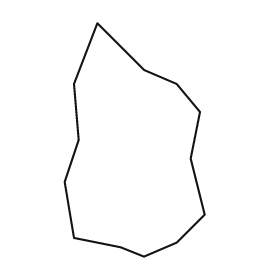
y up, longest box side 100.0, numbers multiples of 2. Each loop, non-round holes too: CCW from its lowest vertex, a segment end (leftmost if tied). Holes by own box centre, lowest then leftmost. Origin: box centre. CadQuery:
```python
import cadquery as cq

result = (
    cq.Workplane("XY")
    .moveTo(4.0, -50.0)
    .lineTo(18.0, -44.0)
    .lineTo(30.0, -32.0)
    .lineTo(24.0, -8.0)
    .lineTo(28.0, 12.0)
    .lineTo(18.0, 24.0)
    .lineTo(4.0, 30.0)
    .lineTo(-16.0, 50.0)
    .lineTo(-26.0, 24.0)
    .lineTo(-24.0, 0.0)
    .lineTo(-30.0, -18.0)
    .lineTo(-26.0, -42.0)
    .lineTo(-6.0, -46.0)
    .close()
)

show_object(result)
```